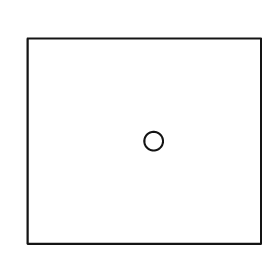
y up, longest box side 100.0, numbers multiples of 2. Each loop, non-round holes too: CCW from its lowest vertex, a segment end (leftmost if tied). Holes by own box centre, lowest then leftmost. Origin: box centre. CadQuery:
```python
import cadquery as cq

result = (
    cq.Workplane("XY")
    .moveTo(-50.0, -44.0)
    .lineTo(50.0, -44.0)
    .lineTo(50.0, 44.0)
    .lineTo(-50.0, 44.0)
    .close()
    .moveTo(4.0, 0.0)
    .circle(4.0)
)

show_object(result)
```